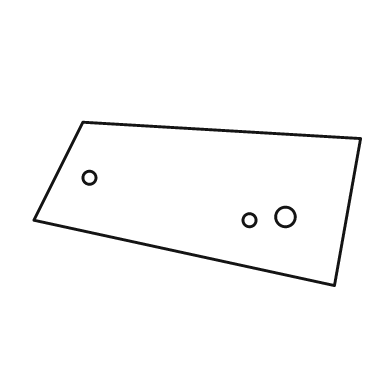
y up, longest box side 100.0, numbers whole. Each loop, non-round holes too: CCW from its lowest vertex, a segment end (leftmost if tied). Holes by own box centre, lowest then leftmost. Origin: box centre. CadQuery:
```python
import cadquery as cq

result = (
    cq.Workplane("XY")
    .moveTo(42.0, -25.0)
    .lineTo(50.0, 20.0)
    .lineTo(-35.0, 25.0)
    .lineTo(-50.0, -5.0)
    .close()
    .moveTo(16.0, -5.0)
    .circle(2.0)
    .moveTo(27.0, -4.0)
    .circle(3.0)
    .moveTo(-33.0, 8.0)
    .circle(2.0)
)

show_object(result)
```